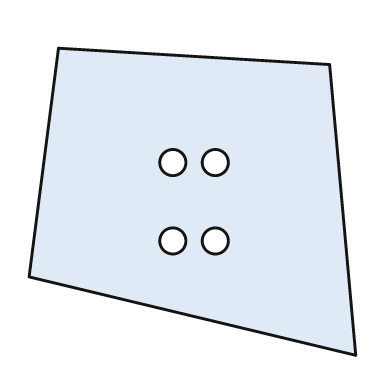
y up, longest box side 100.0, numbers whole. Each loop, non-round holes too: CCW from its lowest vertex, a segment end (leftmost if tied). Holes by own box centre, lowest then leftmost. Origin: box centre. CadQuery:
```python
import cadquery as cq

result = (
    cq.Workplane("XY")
    .moveTo(50.0, -47.0)
    .lineTo(42.0, 42.0)
    .lineTo(-41.0, 47.0)
    .lineTo(-50.0, -23.0)
    .close()
    .moveTo(-6.0, -12.0)
    .circle(4.0)
    .moveTo(7.0, -12.0)
    .circle(4.0)
    .moveTo(-6.0, 12.0)
    .circle(4.0)
    .moveTo(7.0, 12.0)
    .circle(4.0)
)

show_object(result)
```